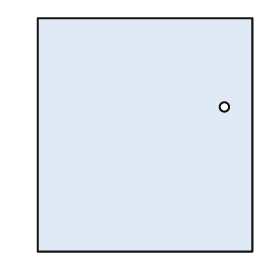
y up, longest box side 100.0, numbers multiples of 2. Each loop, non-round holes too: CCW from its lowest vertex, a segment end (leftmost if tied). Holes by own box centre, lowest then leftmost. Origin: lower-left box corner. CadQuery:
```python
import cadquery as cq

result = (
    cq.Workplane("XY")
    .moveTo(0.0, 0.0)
    .lineTo(92.0, 0.0)
    .lineTo(92.0, 100.0)
    .lineTo(0.0, 100.0)
    .close()
    .moveTo(80.0, 62.0)
    .circle(2.0)
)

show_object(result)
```